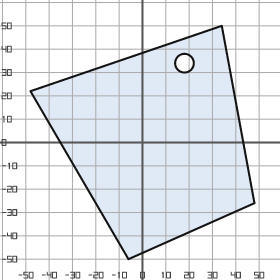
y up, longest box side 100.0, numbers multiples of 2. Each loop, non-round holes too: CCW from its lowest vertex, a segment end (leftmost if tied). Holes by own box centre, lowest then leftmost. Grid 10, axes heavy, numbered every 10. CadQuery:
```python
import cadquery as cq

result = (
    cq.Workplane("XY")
    .moveTo(-6.0, -50.0)
    .lineTo(48.0, -26.0)
    .lineTo(34.0, 50.0)
    .lineTo(-48.0, 22.0)
    .close()
    .moveTo(18.0, 34.0)
    .circle(4.0)
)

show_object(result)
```